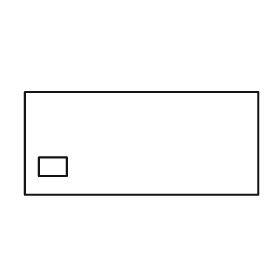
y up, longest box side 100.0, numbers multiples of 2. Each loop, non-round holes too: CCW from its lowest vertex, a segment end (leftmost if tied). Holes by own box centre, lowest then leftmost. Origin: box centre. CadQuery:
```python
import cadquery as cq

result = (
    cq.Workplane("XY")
    .moveTo(-50.0, -22.0)
    .lineTo(50.0, -22.0)
    .lineTo(50.0, 22.0)
    .lineTo(-50.0, 22.0)
    .close()
    .moveTo(-44.0, -14.0)
    .lineTo(-32.0, -14.0)
    .lineTo(-32.0, -6.0)
    .lineTo(-44.0, -6.0)
    .close()
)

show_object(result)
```